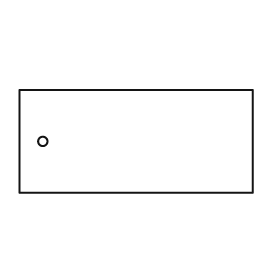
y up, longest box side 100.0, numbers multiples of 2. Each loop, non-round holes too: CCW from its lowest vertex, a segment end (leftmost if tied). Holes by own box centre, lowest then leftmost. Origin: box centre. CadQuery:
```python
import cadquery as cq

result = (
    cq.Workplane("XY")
    .moveTo(-50.0, -22.0)
    .lineTo(50.0, -22.0)
    .lineTo(50.0, 22.0)
    .lineTo(-50.0, 22.0)
    .close()
    .moveTo(-40.0, 0.0)
    .circle(2.0)
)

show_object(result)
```